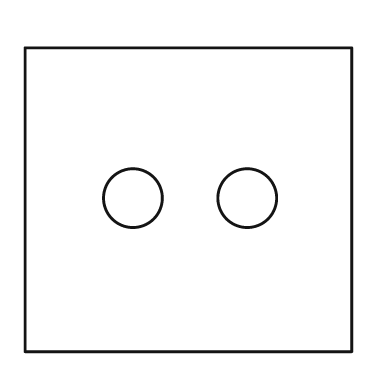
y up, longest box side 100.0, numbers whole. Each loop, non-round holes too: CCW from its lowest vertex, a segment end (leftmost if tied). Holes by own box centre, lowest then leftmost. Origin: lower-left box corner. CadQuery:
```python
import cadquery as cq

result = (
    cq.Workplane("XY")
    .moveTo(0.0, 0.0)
    .lineTo(100.0, 0.0)
    .lineTo(100.0, 93.0)
    .lineTo(0.0, 93.0)
    .close()
    .moveTo(33.0, 47.0)
    .circle(9.0)
    .moveTo(68.0, 47.0)
    .circle(9.0)
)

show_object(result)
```